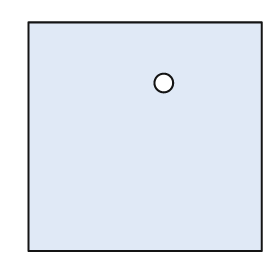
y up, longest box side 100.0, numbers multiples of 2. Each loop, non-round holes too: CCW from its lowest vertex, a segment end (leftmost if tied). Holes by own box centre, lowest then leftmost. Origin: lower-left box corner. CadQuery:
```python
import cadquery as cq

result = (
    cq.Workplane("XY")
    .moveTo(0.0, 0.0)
    .lineTo(100.0, 0.0)
    .lineTo(100.0, 98.0)
    .lineTo(0.0, 98.0)
    .close()
    .moveTo(58.0, 72.0)
    .circle(4.0)
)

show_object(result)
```